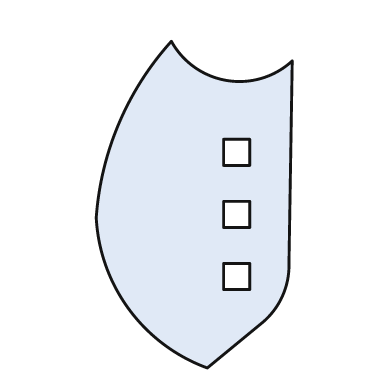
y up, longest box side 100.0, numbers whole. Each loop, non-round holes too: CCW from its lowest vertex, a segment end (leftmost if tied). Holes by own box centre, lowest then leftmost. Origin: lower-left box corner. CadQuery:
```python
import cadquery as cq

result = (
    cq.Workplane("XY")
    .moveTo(34.0, 0.0)
    .lineTo(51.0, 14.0)
    .threePointArc((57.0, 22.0), (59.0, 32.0))
    .lineTo(60.0, 94.0)
    .threePointArc((40.0, 88.0), (23.0, 100.0))
    .threePointArc((7.0, 75.0), (0.0, 46.0))
    .threePointArc((10.0, 18.0), (34.0, 0.0))
    .close()
    .moveTo(39.0, 24.0)
    .lineTo(47.0, 24.0)
    .lineTo(47.0, 32.0)
    .lineTo(39.0, 32.0)
    .close()
    .moveTo(39.0, 43.0)
    .lineTo(47.0, 43.0)
    .lineTo(47.0, 51.0)
    .lineTo(39.0, 51.0)
    .close()
    .moveTo(39.0, 62.0)
    .lineTo(47.0, 62.0)
    .lineTo(47.0, 70.0)
    .lineTo(39.0, 70.0)
    .close()
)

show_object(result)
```